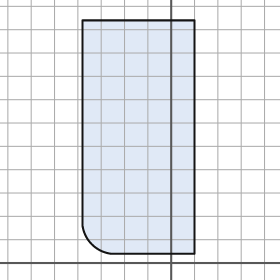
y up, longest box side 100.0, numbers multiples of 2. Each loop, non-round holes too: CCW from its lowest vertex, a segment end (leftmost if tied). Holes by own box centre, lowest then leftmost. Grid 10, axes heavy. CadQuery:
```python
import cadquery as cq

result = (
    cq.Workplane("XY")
    .moveTo(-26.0, 4.0)
    .lineTo(10.0, 4.0)
    .lineTo(10.0, 104.0)
    .lineTo(-38.0, 104.0)
    .lineTo(-38.0, 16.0)
    .threePointArc((-34.0, 8.0), (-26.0, 4.0))
    .close()
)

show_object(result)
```